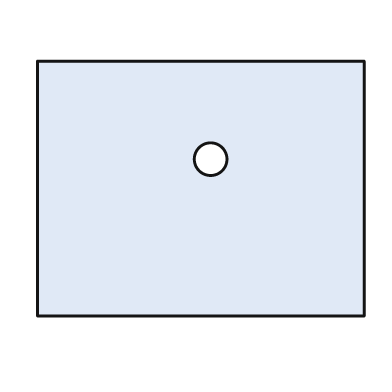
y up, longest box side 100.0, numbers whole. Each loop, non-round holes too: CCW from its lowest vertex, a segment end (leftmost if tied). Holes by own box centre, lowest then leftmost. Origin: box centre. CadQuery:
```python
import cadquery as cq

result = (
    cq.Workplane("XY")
    .moveTo(-50.0, -39.0)
    .lineTo(50.0, -39.0)
    .lineTo(50.0, 39.0)
    .lineTo(-50.0, 39.0)
    .close()
    .moveTo(3.0, 9.0)
    .circle(5.0)
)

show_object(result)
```